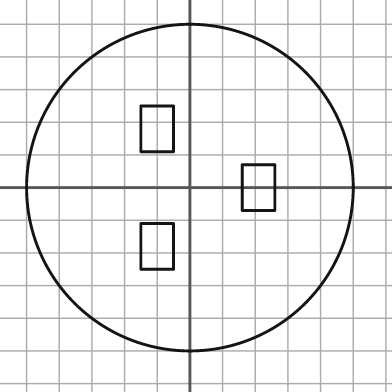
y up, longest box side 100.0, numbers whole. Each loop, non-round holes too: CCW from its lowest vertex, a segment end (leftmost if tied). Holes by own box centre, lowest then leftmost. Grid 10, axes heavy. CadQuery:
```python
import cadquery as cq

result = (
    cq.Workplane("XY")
    .moveTo(0.0, 0.0)
    .circle(50.0)
    .moveTo(-15.0, -25.0)
    .lineTo(-5.0, -25.0)
    .lineTo(-5.0, -11.0)
    .lineTo(-15.0, -11.0)
    .close()
    .moveTo(16.0, -7.0)
    .lineTo(26.0, -7.0)
    .lineTo(26.0, 7.0)
    .lineTo(16.0, 7.0)
    .close()
    .moveTo(-15.0, 11.0)
    .lineTo(-5.0, 11.0)
    .lineTo(-5.0, 25.0)
    .lineTo(-15.0, 25.0)
    .close()
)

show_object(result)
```